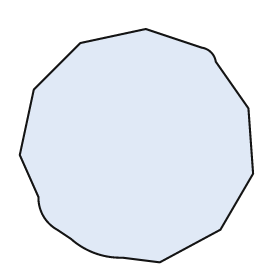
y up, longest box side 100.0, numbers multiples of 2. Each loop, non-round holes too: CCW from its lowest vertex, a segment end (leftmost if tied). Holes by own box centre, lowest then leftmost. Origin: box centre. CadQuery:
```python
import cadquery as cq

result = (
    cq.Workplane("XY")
    .moveTo(10.0, -50.0)
    .lineTo(36.0, -36.0)
    .lineTo(50.0, -12.0)
    .lineTo(48.0, 16.0)
    .lineTo(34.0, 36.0)
    .threePointArc((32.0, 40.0), (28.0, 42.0))
    .lineTo(4.0, 50.0)
    .lineTo(-24.0, 44.0)
    .lineTo(-44.0, 24.0)
    .lineTo(-50.0, -4.0)
    .lineTo(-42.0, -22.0)
    .threePointArc((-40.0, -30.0), (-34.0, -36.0))
    .lineTo(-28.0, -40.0)
    .threePointArc((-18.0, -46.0), (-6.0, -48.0))
    .close()
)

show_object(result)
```